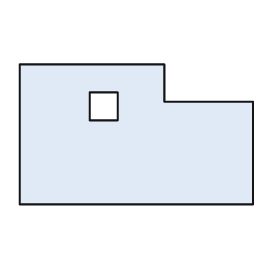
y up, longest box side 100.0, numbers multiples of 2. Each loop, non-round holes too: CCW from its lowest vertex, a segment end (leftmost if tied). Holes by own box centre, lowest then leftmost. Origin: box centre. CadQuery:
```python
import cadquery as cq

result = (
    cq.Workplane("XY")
    .moveTo(-50.0, -30.0)
    .lineTo(50.0, -30.0)
    .lineTo(50.0, 14.0)
    .lineTo(12.0, 14.0)
    .lineTo(12.0, 30.0)
    .lineTo(-50.0, 30.0)
    .close()
    .moveTo(-20.0, 6.0)
    .lineTo(-8.0, 6.0)
    .lineTo(-8.0, 18.0)
    .lineTo(-20.0, 18.0)
    .close()
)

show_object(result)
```